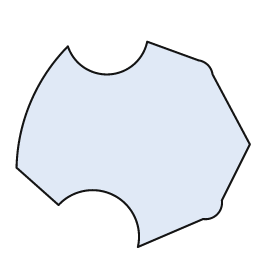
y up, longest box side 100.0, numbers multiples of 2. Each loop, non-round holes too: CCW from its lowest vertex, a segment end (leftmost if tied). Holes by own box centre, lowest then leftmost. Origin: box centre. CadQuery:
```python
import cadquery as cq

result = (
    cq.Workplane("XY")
    .moveTo(2.0, -44.0)
    .lineTo(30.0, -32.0)
    .threePointArc((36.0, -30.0), (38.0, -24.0))
    .lineTo(50.0, 0.0)
    .lineTo(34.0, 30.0)
    .threePointArc((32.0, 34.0), (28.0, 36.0))
    .lineTo(6.0, 44.0)
    .threePointArc((-10.0, 30.0), (-28.0, 42.0))
    .threePointArc((-44.0, 18.0), (-50.0, -10.0))
    .lineTo(-32.0, -26.0)
    .threePointArc((-8.0, -22.0), (2.0, -44.0))
    .close()
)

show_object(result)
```